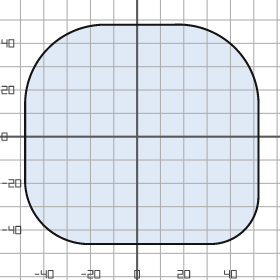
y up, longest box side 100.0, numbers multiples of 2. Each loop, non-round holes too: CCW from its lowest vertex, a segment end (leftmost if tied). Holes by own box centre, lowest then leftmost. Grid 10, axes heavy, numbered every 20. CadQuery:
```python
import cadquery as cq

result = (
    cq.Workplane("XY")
    .moveTo(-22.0, -46.0)
    .lineTo(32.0, -46.0)
    .threePointArc((46.0, -40.0), (52.0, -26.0))
    .lineTo(52.0, 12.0)
    .threePointArc((42.0, 38.0), (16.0, 48.0))
    .lineTo(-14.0, 48.0)
    .threePointArc((-38.0, 38.0), (-48.0, 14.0))
    .lineTo(-48.0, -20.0)
    .threePointArc((-40.0, -38.0), (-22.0, -46.0))
    .close()
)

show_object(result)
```